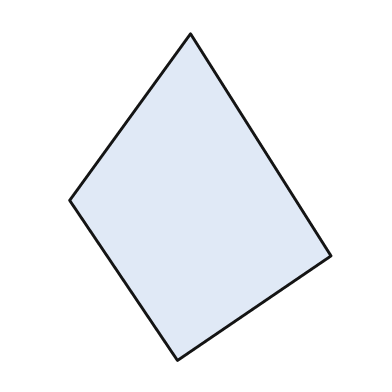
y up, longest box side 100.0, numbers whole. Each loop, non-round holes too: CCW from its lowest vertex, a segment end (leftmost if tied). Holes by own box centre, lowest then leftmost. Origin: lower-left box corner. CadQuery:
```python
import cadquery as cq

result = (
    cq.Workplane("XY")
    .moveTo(33.0, 0.0)
    .lineTo(80.0, 32.0)
    .lineTo(37.0, 100.0)
    .lineTo(0.0, 49.0)
    .close()
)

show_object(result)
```